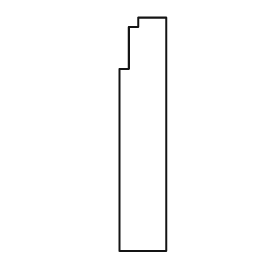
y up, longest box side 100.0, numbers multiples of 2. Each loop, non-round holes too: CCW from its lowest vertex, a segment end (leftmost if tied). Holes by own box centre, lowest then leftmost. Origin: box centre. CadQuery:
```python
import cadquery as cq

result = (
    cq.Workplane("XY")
    .moveTo(-10.0, -50.0)
    .lineTo(10.0, -50.0)
    .lineTo(10.0, 50.0)
    .lineTo(-2.0, 50.0)
    .lineTo(-2.0, 46.0)
    .lineTo(-6.0, 46.0)
    .lineTo(-6.0, 28.0)
    .lineTo(-10.0, 28.0)
    .close()
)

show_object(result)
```